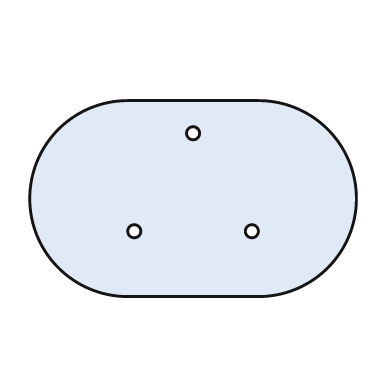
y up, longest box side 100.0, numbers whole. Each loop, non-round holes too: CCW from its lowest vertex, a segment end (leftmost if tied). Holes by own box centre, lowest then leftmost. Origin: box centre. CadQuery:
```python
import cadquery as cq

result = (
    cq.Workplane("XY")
    .moveTo(-20.0, -30.0)
    .lineTo(20.0, -30.0)
    .threePointArc((50.0, 0.0), (20.0, 30.0))
    .lineTo(-20.0, 30.0)
    .threePointArc((-50.0, 0.0), (-20.0, -30.0))
    .close()
    .moveTo(-18.0, -10.0)
    .circle(2.0)
    .moveTo(18.0, -10.0)
    .circle(2.0)
    .moveTo(0.0, 20.0)
    .circle(2.0)
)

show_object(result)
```